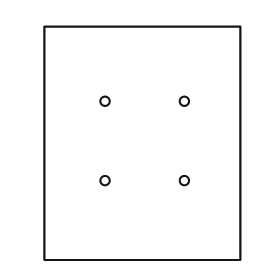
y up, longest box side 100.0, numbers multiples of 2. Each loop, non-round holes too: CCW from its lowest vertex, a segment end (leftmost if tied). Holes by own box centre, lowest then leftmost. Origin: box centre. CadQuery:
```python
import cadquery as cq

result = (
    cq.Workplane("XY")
    .moveTo(-42.0, -50.0)
    .lineTo(42.0, -50.0)
    .lineTo(42.0, 50.0)
    .lineTo(-42.0, 50.0)
    .close()
    .moveTo(-16.0, -16.0)
    .circle(2.0)
    .moveTo(18.0, -16.0)
    .circle(2.0)
    .moveTo(-16.0, 18.0)
    .circle(2.0)
    .moveTo(18.0, 18.0)
    .circle(2.0)
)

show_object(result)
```